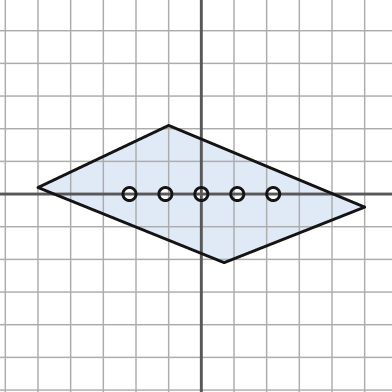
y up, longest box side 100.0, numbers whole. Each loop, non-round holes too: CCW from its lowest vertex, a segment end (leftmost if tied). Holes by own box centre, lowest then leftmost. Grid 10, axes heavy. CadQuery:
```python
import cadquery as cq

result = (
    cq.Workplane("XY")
    .moveTo(7.0, -21.0)
    .lineTo(50.0, -4.0)
    .lineTo(-10.0, 21.0)
    .lineTo(-50.0, 2.0)
    .close()
    .moveTo(-22.0, 0.0)
    .circle(2.0)
    .moveTo(-11.0, 0.0)
    .circle(2.0)
    .moveTo(0.0, 0.0)
    .circle(2.0)
    .moveTo(11.0, 0.0)
    .circle(2.0)
    .moveTo(22.0, 0.0)
    .circle(2.0)
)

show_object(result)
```